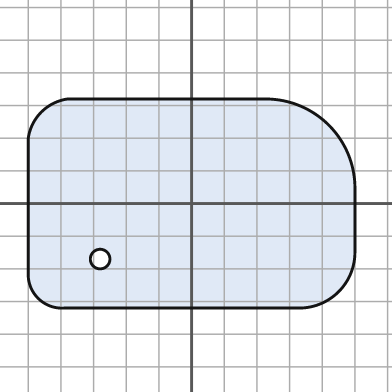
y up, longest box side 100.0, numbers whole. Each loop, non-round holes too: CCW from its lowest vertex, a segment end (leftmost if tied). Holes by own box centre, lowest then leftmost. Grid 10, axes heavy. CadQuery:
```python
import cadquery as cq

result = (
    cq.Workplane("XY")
    .moveTo(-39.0, -32.0)
    .lineTo(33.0, -32.0)
    .threePointArc((45.0, -27.0), (50.0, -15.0))
    .lineTo(50.0, 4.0)
    .threePointArc((42.0, 24.0), (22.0, 32.0))
    .lineTo(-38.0, 32.0)
    .threePointArc((-46.0, 28.0), (-50.0, 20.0))
    .lineTo(-50.0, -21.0)
    .threePointArc((-47.0, -29.0), (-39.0, -32.0))
    .close()
    .moveTo(-28.0, -17.0)
    .circle(3.0)
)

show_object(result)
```